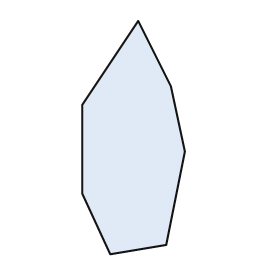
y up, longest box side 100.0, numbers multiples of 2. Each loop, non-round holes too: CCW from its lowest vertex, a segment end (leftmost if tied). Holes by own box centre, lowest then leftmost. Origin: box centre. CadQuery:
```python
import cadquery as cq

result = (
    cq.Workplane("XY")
    .moveTo(-10.0, -50.0)
    .lineTo(14.0, -46.0)
    .lineTo(22.0, -6.0)
    .lineTo(16.0, 22.0)
    .lineTo(2.0, 50.0)
    .lineTo(-22.0, 14.0)
    .lineTo(-22.0, -24.0)
    .close()
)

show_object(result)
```